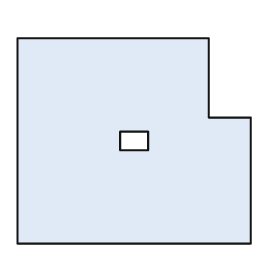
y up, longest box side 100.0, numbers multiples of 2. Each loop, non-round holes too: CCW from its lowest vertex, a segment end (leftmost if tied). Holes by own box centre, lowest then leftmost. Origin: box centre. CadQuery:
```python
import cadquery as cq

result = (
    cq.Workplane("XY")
    .moveTo(-50.0, -44.0)
    .lineTo(50.0, -44.0)
    .lineTo(50.0, 10.0)
    .lineTo(32.0, 10.0)
    .lineTo(32.0, 44.0)
    .lineTo(-50.0, 44.0)
    .close()
    .moveTo(-6.0, -4.0)
    .lineTo(6.0, -4.0)
    .lineTo(6.0, 4.0)
    .lineTo(-6.0, 4.0)
    .close()
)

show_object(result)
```